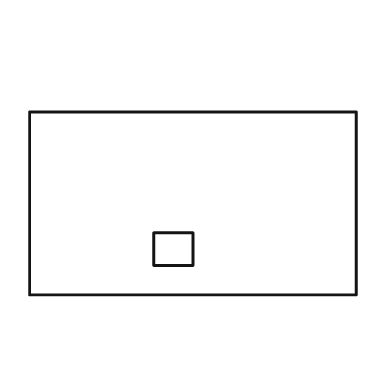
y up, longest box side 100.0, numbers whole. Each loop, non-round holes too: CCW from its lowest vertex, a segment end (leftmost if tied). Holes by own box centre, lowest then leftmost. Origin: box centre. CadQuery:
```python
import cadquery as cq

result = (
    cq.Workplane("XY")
    .moveTo(-50.0, -28.0)
    .lineTo(50.0, -28.0)
    .lineTo(50.0, 28.0)
    .lineTo(-50.0, 28.0)
    .close()
    .moveTo(-12.0, -19.0)
    .lineTo(0.0, -19.0)
    .lineTo(0.0, -9.0)
    .lineTo(-12.0, -9.0)
    .close()
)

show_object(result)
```